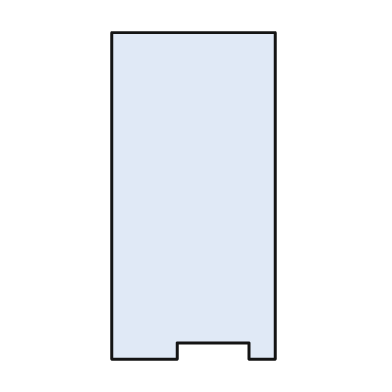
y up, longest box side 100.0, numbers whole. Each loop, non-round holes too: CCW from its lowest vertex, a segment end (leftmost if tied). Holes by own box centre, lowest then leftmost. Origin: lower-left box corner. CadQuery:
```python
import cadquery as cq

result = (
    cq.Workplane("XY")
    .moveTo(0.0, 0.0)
    .lineTo(20.0, 0.0)
    .lineTo(20.0, 5.0)
    .lineTo(42.0, 5.0)
    .lineTo(42.0, 0.0)
    .lineTo(50.0, 0.0)
    .lineTo(50.0, 100.0)
    .lineTo(0.0, 100.0)
    .close()
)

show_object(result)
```